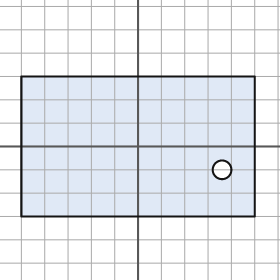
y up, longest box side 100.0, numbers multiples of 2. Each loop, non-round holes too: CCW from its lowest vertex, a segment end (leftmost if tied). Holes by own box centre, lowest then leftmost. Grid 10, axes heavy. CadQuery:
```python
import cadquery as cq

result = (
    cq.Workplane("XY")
    .moveTo(-50.0, -30.0)
    .lineTo(50.0, -30.0)
    .lineTo(50.0, 30.0)
    .lineTo(-50.0, 30.0)
    .close()
    .moveTo(36.0, -10.0)
    .circle(4.0)
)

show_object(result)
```